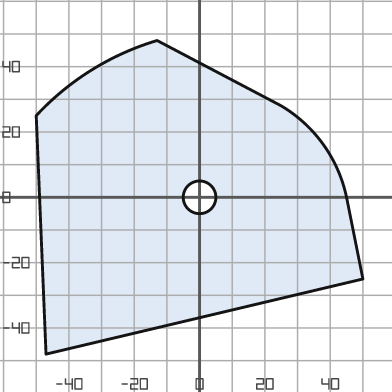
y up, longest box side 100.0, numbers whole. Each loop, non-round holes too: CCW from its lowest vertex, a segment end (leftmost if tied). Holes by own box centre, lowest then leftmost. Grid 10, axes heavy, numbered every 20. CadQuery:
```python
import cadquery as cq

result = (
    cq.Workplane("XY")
    .moveTo(-47.0, -48.0)
    .lineTo(50.0, -25.0)
    .lineTo(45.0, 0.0)
    .threePointArc((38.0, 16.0), (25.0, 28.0))
    .lineTo(-13.0, 48.0)
    .threePointArc((-33.0, 39.0), (-50.0, 25.0))
    .close()
    .moveTo(0.0, 0.0)
    .circle(5.0)
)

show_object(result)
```